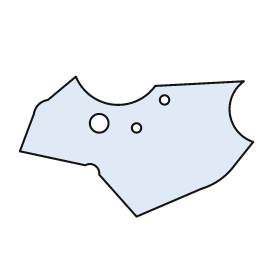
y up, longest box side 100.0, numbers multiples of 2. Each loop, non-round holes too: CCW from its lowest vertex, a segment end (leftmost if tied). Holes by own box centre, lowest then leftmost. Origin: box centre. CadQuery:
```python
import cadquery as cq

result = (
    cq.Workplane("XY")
    .moveTo(0.0, -30.0)
    .lineTo(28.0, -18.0)
    .threePointArc((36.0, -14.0), (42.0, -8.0))
    .lineTo(50.0, 2.0)
    .threePointArc((40.0, 14.0), (46.0, 28.0))
    .lineTo(8.0, 26.0)
    .threePointArc((-10.0, 18.0), (-26.0, 30.0))
    .lineTo(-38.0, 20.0)
    .threePointArc((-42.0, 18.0), (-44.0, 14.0))
    .lineTo(-50.0, -2.0)
    .lineTo(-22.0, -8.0)
    .threePointArc((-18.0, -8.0), (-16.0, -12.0))
    .close()
    .moveTo(0.0, 8.0)
    .circle(2.0)
    .moveTo(-16.0, 10.0)
    .circle(4.0)
    .moveTo(12.0, 20.0)
    .circle(2.0)
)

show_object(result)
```